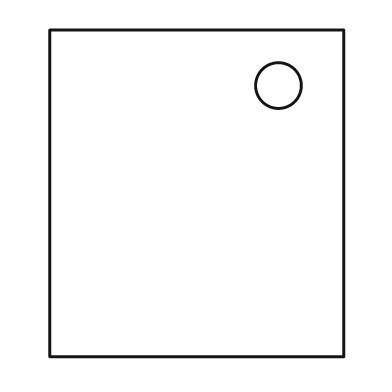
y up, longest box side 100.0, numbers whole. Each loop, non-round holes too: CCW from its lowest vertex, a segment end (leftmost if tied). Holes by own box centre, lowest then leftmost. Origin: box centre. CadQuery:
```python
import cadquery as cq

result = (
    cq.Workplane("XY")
    .moveTo(-45.0, -50.0)
    .lineTo(45.0, -50.0)
    .lineTo(45.0, 50.0)
    .lineTo(-45.0, 50.0)
    .close()
    .moveTo(25.0, 33.0)
    .circle(7.0)
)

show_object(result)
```